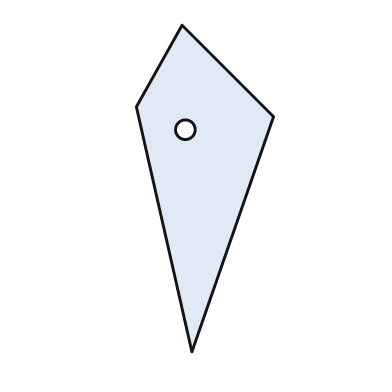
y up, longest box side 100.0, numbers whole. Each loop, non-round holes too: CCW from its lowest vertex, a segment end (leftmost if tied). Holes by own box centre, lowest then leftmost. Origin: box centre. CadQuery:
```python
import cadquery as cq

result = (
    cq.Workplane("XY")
    .moveTo(-4.0, -50.0)
    .lineTo(21.0, 22.0)
    .lineTo(-7.0, 50.0)
    .lineTo(-21.0, 25.0)
    .close()
    .moveTo(-6.0, 18.0)
    .circle(3.0)
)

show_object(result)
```